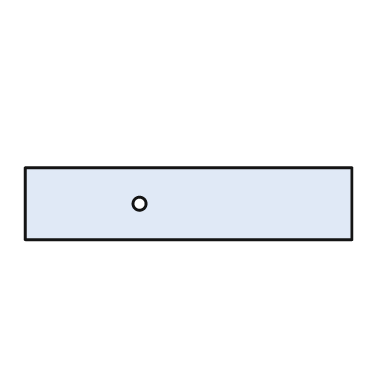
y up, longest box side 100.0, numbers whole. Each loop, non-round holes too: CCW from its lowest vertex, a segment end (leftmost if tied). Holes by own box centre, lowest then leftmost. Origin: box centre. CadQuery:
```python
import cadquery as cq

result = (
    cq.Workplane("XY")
    .moveTo(-50.0, -11.0)
    .lineTo(50.0, -11.0)
    .lineTo(50.0, 11.0)
    .lineTo(-50.0, 11.0)
    .close()
    .moveTo(-15.0, 0.0)
    .circle(2.0)
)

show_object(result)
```